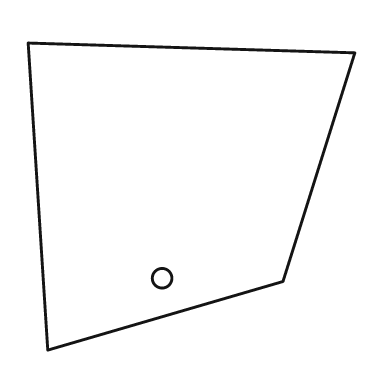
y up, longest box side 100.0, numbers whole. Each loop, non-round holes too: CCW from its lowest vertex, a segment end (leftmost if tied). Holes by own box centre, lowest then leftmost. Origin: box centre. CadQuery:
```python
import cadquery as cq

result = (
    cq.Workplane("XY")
    .moveTo(-44.0, -47.0)
    .lineTo(28.0, -26.0)
    .lineTo(50.0, 44.0)
    .lineTo(-50.0, 47.0)
    .close()
    .moveTo(-9.0, -25.0)
    .circle(3.0)
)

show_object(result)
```